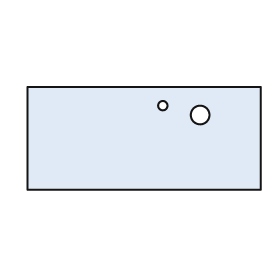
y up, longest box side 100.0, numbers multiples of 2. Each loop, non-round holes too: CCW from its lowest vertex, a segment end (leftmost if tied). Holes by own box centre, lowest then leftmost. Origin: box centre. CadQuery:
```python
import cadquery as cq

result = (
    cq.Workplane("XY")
    .moveTo(-50.0, -22.0)
    .lineTo(50.0, -22.0)
    .lineTo(50.0, 22.0)
    .lineTo(-50.0, 22.0)
    .close()
    .moveTo(24.0, 10.0)
    .circle(4.0)
    .moveTo(8.0, 14.0)
    .circle(2.0)
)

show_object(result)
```